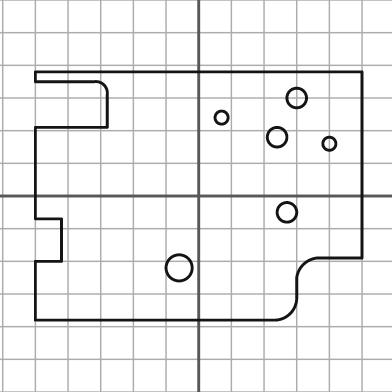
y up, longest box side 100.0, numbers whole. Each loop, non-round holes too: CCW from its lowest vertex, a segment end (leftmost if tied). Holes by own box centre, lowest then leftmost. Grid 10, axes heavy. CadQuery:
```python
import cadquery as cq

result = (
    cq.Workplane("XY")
    .moveTo(-50.0, -38.0)
    .lineTo(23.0, -38.0)
    .threePointArc((28.0, -36.0), (30.0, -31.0))
    .lineTo(30.0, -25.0)
    .threePointArc((32.0, -21.0), (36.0, -19.0))
    .lineTo(50.0, -19.0)
    .lineTo(50.0, 38.0)
    .lineTo(-50.0, 38.0)
    .lineTo(-50.0, 35.0)
    .lineTo(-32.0, 35.0)
    .threePointArc((-29.0, 34.0), (-28.0, 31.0))
    .lineTo(-28.0, 21.0)
    .lineTo(-50.0, 21.0)
    .lineTo(-50.0, -7.0)
    .lineTo(-42.0, -7.0)
    .lineTo(-42.0, -20.0)
    .lineTo(-50.0, -20.0)
    .close()
    .moveTo(-6.0, -22.0)
    .circle(4.0)
    .moveTo(27.0, -5.0)
    .circle(3.0)
    .moveTo(40.0, 16.0)
    .circle(2.0)
    .moveTo(24.0, 18.0)
    .circle(3.0)
    .moveTo(7.0, 24.0)
    .circle(2.0)
    .moveTo(30.0, 30.0)
    .circle(3.0)
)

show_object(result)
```